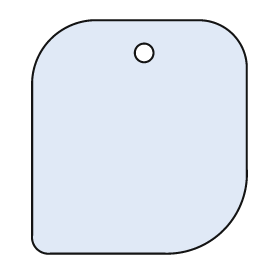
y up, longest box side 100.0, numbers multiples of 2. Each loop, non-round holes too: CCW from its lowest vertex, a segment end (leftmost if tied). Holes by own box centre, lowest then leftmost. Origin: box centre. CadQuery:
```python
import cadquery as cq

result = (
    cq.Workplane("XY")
    .moveTo(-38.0, -50.0)
    .lineTo(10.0, -50.0)
    .threePointArc((36.0, -40.0), (46.0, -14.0))
    .lineTo(46.0, 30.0)
    .threePointArc((40.0, 44.0), (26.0, 50.0))
    .lineTo(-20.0, 50.0)
    .threePointArc((-38.0, 42.0), (-46.0, 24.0))
    .lineTo(-46.0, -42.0)
    .threePointArc((-44.0, -48.0), (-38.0, -50.0))
    .close()
    .moveTo(2.0, 36.0)
    .circle(4.0)
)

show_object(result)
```